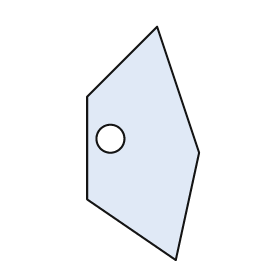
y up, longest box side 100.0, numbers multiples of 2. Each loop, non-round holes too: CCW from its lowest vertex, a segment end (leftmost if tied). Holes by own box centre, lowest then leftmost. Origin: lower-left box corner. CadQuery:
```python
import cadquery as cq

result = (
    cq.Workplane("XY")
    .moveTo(38.0, 0.0)
    .lineTo(48.0, 46.0)
    .lineTo(30.0, 100.0)
    .lineTo(0.0, 70.0)
    .lineTo(0.0, 26.0)
    .close()
    .moveTo(10.0, 52.0)
    .circle(6.0)
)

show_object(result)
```